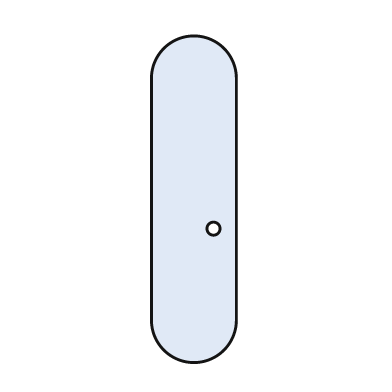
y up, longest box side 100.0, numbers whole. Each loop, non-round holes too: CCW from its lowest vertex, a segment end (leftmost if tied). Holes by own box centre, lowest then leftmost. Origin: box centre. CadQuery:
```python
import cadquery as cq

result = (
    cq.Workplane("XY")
    .moveTo(-13.0, -37.0)
    .threePointArc((0.0, -50.0), (13.0, -37.0))
    .lineTo(13.0, 37.0)
    .threePointArc((0.0, 50.0), (-13.0, 37.0))
    .close()
    .moveTo(6.0, -9.0)
    .circle(2.0)
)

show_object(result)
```